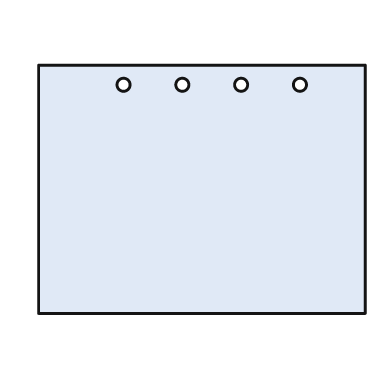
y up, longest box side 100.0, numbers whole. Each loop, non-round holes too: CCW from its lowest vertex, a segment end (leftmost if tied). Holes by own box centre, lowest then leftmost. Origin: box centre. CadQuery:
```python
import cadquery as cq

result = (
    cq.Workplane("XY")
    .moveTo(-50.0, -38.0)
    .lineTo(50.0, -38.0)
    .lineTo(50.0, 38.0)
    .lineTo(-50.0, 38.0)
    .close()
    .moveTo(-24.0, 32.0)
    .circle(2.0)
    .moveTo(-6.0, 32.0)
    .circle(2.0)
    .moveTo(12.0, 32.0)
    .circle(2.0)
    .moveTo(30.0, 32.0)
    .circle(2.0)
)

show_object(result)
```